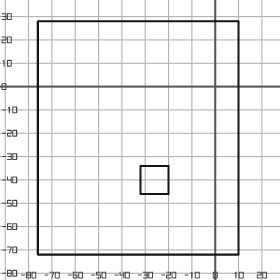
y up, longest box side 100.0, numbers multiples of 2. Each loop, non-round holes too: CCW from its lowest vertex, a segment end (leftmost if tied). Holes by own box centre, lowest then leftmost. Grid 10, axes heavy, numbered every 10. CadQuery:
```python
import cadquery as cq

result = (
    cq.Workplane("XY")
    .moveTo(-76.0, -72.0)
    .lineTo(10.0, -72.0)
    .lineTo(10.0, 28.0)
    .lineTo(-76.0, 28.0)
    .close()
    .moveTo(-32.0, -46.0)
    .lineTo(-20.0, -46.0)
    .lineTo(-20.0, -34.0)
    .lineTo(-32.0, -34.0)
    .close()
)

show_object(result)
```